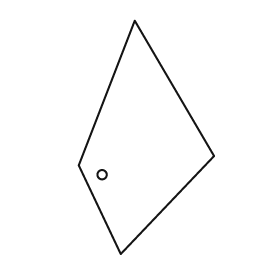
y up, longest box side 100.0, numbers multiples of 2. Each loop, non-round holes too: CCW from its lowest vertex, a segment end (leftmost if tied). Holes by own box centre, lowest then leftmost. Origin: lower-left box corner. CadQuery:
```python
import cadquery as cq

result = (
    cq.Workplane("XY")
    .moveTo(18.0, 0.0)
    .lineTo(58.0, 42.0)
    .lineTo(24.0, 100.0)
    .lineTo(0.0, 38.0)
    .close()
    .moveTo(10.0, 34.0)
    .circle(2.0)
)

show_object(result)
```